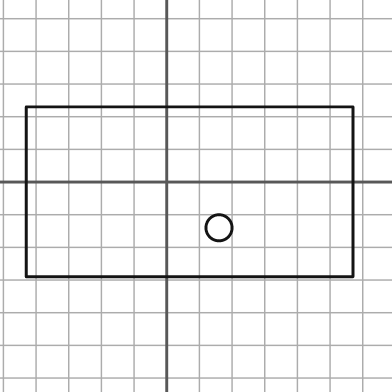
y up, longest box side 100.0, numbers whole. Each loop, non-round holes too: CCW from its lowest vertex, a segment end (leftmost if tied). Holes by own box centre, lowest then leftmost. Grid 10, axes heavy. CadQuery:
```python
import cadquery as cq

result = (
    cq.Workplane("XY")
    .moveTo(-43.0, -29.0)
    .lineTo(57.0, -29.0)
    .lineTo(57.0, 23.0)
    .lineTo(-43.0, 23.0)
    .close()
    .moveTo(16.0, -14.0)
    .circle(4.0)
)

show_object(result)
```